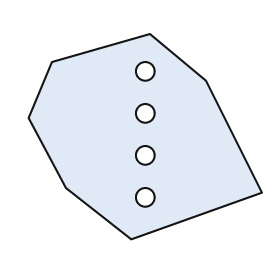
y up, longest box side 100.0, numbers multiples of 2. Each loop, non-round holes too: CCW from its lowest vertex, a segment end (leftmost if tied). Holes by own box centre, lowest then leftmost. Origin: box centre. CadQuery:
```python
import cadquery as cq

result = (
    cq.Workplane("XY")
    .moveTo(-6.0, -44.0)
    .lineTo(50.0, -24.0)
    .lineTo(26.0, 24.0)
    .lineTo(2.0, 44.0)
    .lineTo(-40.0, 32.0)
    .lineTo(-50.0, 8.0)
    .lineTo(-34.0, -22.0)
    .close()
    .moveTo(0.0, -26.0)
    .circle(4.0)
    .moveTo(0.0, -8.0)
    .circle(4.0)
    .moveTo(0.0, 10.0)
    .circle(4.0)
    .moveTo(0.0, 28.0)
    .circle(4.0)
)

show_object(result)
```